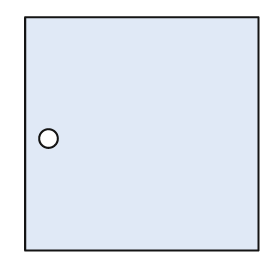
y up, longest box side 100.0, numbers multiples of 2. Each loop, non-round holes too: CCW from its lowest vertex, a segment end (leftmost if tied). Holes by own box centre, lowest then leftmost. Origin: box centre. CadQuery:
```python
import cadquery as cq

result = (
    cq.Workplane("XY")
    .moveTo(-50.0, -50.0)
    .lineTo(50.0, -50.0)
    .lineTo(50.0, 50.0)
    .lineTo(-50.0, 50.0)
    .close()
    .moveTo(-40.0, -2.0)
    .circle(4.0)
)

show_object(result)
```